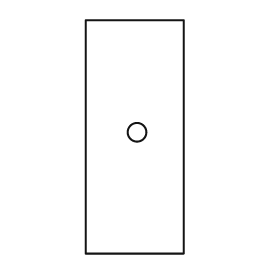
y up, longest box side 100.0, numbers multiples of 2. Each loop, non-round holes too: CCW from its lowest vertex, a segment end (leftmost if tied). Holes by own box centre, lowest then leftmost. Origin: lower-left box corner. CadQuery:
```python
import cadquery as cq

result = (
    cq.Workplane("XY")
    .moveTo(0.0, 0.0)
    .lineTo(42.0, 0.0)
    .lineTo(42.0, 100.0)
    .lineTo(0.0, 100.0)
    .close()
    .moveTo(22.0, 52.0)
    .circle(4.0)
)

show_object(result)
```